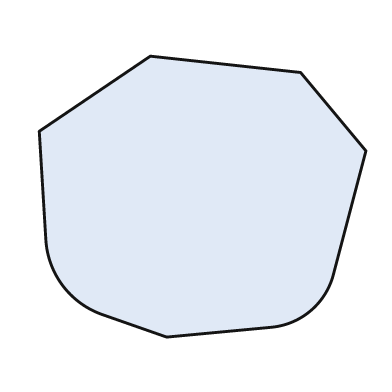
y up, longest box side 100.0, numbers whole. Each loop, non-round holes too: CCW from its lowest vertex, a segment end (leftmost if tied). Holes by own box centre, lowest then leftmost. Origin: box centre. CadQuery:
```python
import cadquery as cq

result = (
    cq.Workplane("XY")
    .moveTo(-11.0, -43.0)
    .lineTo(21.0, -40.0)
    .threePointArc((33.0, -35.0), (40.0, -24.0))
    .lineTo(50.0, 14.0)
    .lineTo(30.0, 38.0)
    .lineTo(-16.0, 43.0)
    .lineTo(-50.0, 20.0)
    .lineTo(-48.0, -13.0)
    .threePointArc((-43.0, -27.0), (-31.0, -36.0))
    .close()
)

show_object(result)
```